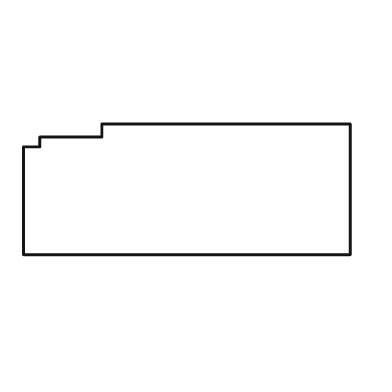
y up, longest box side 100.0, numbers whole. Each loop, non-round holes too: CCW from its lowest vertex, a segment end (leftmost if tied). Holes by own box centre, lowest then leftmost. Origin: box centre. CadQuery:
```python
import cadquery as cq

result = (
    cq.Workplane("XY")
    .moveTo(-50.0, -20.0)
    .lineTo(50.0, -20.0)
    .lineTo(50.0, 20.0)
    .lineTo(-26.0, 20.0)
    .lineTo(-26.0, 16.0)
    .lineTo(-45.0, 16.0)
    .lineTo(-45.0, 13.0)
    .lineTo(-50.0, 13.0)
    .close()
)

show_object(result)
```